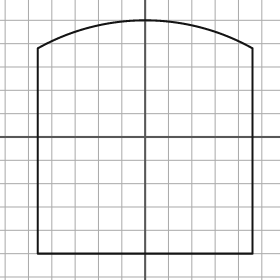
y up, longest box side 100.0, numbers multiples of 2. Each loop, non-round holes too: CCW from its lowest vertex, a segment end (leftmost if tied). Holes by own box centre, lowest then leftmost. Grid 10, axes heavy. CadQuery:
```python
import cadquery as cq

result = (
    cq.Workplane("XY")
    .moveTo(-46.0, -50.0)
    .lineTo(46.0, -50.0)
    .lineTo(46.0, 38.0)
    .threePointArc((0.0, 50.0), (-46.0, 38.0))
    .close()
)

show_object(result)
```